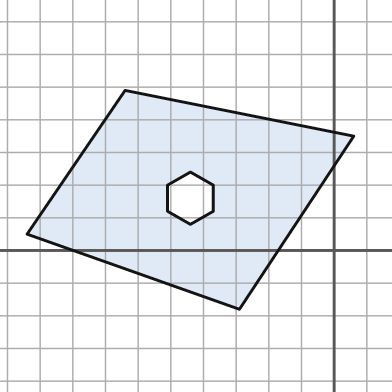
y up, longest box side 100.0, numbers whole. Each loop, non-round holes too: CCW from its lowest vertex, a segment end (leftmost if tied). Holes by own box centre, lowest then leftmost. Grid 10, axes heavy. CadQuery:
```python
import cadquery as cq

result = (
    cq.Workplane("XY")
    .moveTo(-29.0, -18.0)
    .lineTo(6.0, 35.0)
    .lineTo(-64.0, 49.0)
    .lineTo(-94.0, 5.0)
    .close()
    .moveTo(-44.0, 8.0)
    .lineTo(-37.0, 12.0)
    .lineTo(-37.0, 20.0)
    .lineTo(-44.0, 24.0)
    .lineTo(-51.0, 20.0)
    .lineTo(-51.0, 12.0)
    .close()
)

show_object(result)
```